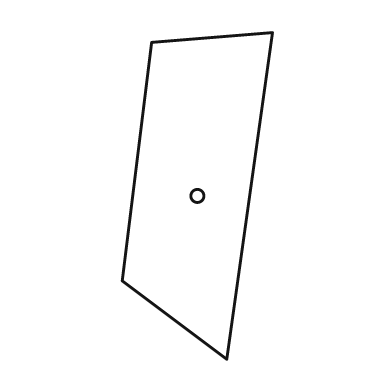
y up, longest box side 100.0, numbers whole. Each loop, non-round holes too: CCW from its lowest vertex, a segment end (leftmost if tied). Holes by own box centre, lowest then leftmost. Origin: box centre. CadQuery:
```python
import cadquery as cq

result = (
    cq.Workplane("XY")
    .moveTo(9.0, -50.0)
    .lineTo(23.0, 50.0)
    .lineTo(-14.0, 47.0)
    .lineTo(-23.0, -26.0)
    .close()
    .moveTo(0.0, 0.0)
    .circle(2.0)
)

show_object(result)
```